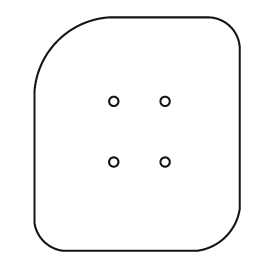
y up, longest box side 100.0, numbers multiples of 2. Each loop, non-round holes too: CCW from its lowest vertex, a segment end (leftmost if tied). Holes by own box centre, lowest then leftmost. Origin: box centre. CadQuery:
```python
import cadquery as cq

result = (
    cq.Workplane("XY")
    .moveTo(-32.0, -50.0)
    .lineTo(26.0, -50.0)
    .threePointArc((38.0, -44.0), (44.0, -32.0))
    .lineTo(44.0, 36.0)
    .threePointArc((40.0, 46.0), (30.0, 50.0))
    .lineTo(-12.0, 50.0)
    .threePointArc((-34.0, 40.0), (-44.0, 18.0))
    .lineTo(-44.0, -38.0)
    .threePointArc((-40.0, -46.0), (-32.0, -50.0))
    .close()
    .moveTo(-10.0, -12.0)
    .circle(2.0)
    .moveTo(12.0, -12.0)
    .circle(2.0)
    .moveTo(-10.0, 14.0)
    .circle(2.0)
    .moveTo(12.0, 14.0)
    .circle(2.0)
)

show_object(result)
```